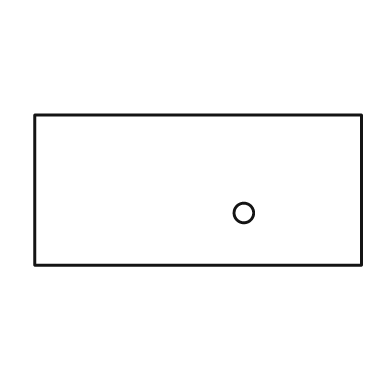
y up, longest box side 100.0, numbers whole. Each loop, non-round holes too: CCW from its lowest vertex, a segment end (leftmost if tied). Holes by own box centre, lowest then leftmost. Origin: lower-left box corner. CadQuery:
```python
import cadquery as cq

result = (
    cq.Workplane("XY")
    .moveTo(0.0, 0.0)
    .lineTo(100.0, 0.0)
    .lineTo(100.0, 46.0)
    .lineTo(0.0, 46.0)
    .close()
    .moveTo(64.0, 16.0)
    .circle(3.0)
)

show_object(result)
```